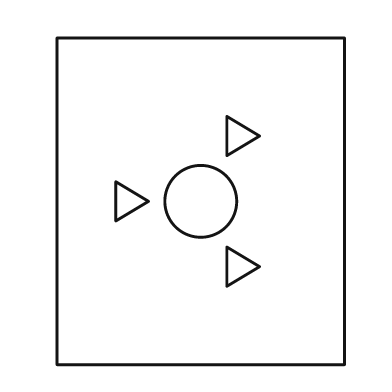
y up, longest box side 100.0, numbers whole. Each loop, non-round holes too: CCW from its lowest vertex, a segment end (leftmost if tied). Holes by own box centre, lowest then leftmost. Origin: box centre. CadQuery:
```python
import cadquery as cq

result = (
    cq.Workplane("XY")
    .moveTo(-44.0, -50.0)
    .lineTo(44.0, -50.0)
    .lineTo(44.0, 50.0)
    .lineTo(-44.0, 50.0)
    .close()
    .moveTo(8.0, -26.0)
    .lineTo(18.0, -20.0)
    .lineTo(8.0, -14.0)
    .close()
    .moveTo(-26.0, -6.0)
    .lineTo(-16.0, 0.0)
    .lineTo(-26.0, 6.0)
    .close()
    .moveTo(0.0, 0.0)
    .circle(11.0)
    .moveTo(8.0, 14.0)
    .lineTo(18.0, 20.0)
    .lineTo(8.0, 26.0)
    .close()
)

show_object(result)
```